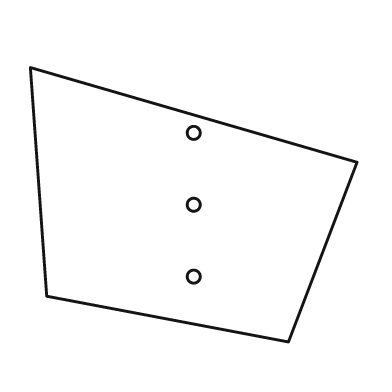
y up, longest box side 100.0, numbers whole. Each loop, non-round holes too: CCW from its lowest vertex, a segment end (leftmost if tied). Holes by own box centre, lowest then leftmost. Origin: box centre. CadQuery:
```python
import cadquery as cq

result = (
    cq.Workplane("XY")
    .moveTo(29.0, -42.0)
    .lineTo(50.0, 13.0)
    .lineTo(-50.0, 42.0)
    .lineTo(-45.0, -28.0)
    .close()
    .moveTo(0.0, -22.0)
    .circle(2.0)
    .moveTo(0.0, 0.0)
    .circle(2.0)
    .moveTo(0.0, 22.0)
    .circle(2.0)
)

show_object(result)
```